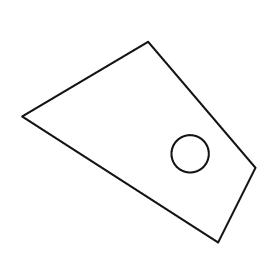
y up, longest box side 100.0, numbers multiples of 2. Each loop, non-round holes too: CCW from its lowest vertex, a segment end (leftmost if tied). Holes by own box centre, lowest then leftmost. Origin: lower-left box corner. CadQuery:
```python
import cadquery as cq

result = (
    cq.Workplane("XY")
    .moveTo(84.0, 0.0)
    .lineTo(100.0, 32.0)
    .lineTo(54.0, 86.0)
    .lineTo(0.0, 54.0)
    .close()
    .moveTo(72.0, 38.0)
    .circle(8.0)
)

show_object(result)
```